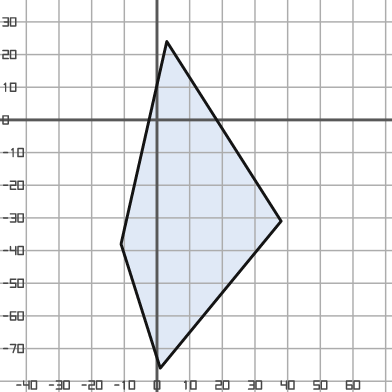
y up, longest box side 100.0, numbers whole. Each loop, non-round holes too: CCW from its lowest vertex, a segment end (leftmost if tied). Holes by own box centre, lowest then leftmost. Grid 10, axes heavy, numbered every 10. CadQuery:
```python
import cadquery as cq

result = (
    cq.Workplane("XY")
    .moveTo(1.0, -76.0)
    .lineTo(38.0, -31.0)
    .lineTo(3.0, 24.0)
    .lineTo(-11.0, -38.0)
    .close()
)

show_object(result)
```